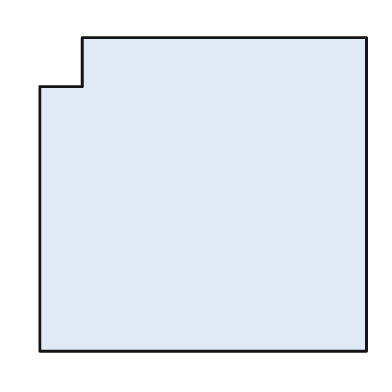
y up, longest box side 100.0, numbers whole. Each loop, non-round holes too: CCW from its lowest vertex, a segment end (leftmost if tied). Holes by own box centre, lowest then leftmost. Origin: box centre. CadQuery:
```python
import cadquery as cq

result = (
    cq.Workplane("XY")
    .moveTo(-50.0, -48.0)
    .lineTo(50.0, -48.0)
    .lineTo(50.0, 48.0)
    .lineTo(-37.0, 48.0)
    .lineTo(-37.0, 33.0)
    .lineTo(-50.0, 33.0)
    .close()
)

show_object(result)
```